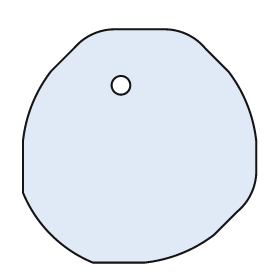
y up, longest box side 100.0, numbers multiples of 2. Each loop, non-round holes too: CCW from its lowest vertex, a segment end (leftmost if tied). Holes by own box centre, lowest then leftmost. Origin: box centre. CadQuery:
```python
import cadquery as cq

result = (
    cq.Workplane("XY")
    .moveTo(-20.0, -50.0)
    .lineTo(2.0, -50.0)
    .threePointArc((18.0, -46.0), (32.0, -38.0))
    .lineTo(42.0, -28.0)
    .threePointArc((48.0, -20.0), (50.0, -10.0))
    .lineTo(50.0, 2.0)
    .threePointArc((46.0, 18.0), (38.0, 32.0))
    .lineTo(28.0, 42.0)
    .threePointArc((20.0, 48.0), (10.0, 50.0))
    .lineTo(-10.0, 50.0)
    .threePointArc((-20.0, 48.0), (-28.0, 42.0))
    .lineTo(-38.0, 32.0)
    .threePointArc((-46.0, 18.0), (-50.0, 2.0))
    .lineTo(-50.0, -20.0)
    .threePointArc((-38.0, -38.0), (-20.0, -50.0))
    .close()
    .moveTo(-8.0, 26.0)
    .circle(4.0)
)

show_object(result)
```